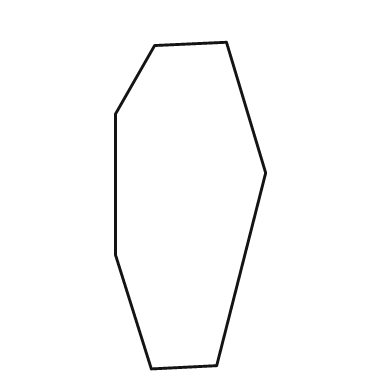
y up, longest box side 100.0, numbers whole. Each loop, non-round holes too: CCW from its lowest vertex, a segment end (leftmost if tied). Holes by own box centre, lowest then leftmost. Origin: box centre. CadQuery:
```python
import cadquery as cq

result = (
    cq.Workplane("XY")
    .moveTo(-12.0, -50.0)
    .lineTo(8.0, -49.0)
    .lineTo(23.0, 10.0)
    .lineTo(11.0, 50.0)
    .lineTo(-11.0, 49.0)
    .lineTo(-23.0, 28.0)
    .lineTo(-23.0, -15.0)
    .close()
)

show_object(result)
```